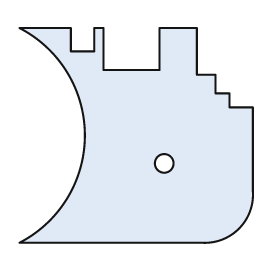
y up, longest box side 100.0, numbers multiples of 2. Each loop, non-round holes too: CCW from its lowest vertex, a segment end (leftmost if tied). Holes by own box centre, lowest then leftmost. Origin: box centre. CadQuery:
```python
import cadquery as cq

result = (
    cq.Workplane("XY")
    .moveTo(-50.0, -46.0)
    .lineTo(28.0, -46.0)
    .threePointArc((44.0, -40.0), (50.0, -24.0))
    .lineTo(50.0, 12.0)
    .lineTo(40.0, 12.0)
    .lineTo(40.0, 18.0)
    .lineTo(34.0, 18.0)
    .lineTo(34.0, 26.0)
    .lineTo(26.0, 26.0)
    .lineTo(26.0, 46.0)
    .lineTo(10.0, 46.0)
    .lineTo(10.0, 28.0)
    .lineTo(-14.0, 28.0)
    .lineTo(-14.0, 46.0)
    .lineTo(-18.0, 46.0)
    .lineTo(-18.0, 36.0)
    .lineTo(-28.0, 36.0)
    .lineTo(-28.0, 46.0)
    .lineTo(-50.0, 46.0)
    .threePointArc((-22.0, 0.0), (-50.0, -46.0))
    .close()
    .moveTo(12.0, -12.0)
    .circle(4.0)
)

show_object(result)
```